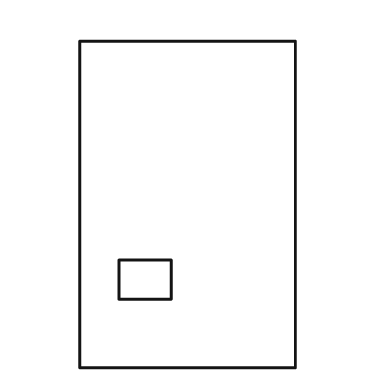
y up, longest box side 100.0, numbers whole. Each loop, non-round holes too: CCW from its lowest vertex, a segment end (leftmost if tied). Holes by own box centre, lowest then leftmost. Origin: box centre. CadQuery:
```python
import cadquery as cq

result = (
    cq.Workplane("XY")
    .moveTo(-33.0, -50.0)
    .lineTo(33.0, -50.0)
    .lineTo(33.0, 50.0)
    .lineTo(-33.0, 50.0)
    .close()
    .moveTo(-21.0, -29.0)
    .lineTo(-5.0, -29.0)
    .lineTo(-5.0, -17.0)
    .lineTo(-21.0, -17.0)
    .close()
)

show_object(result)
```